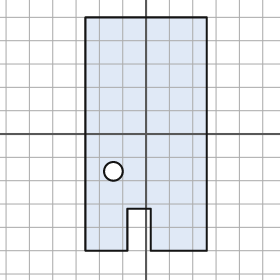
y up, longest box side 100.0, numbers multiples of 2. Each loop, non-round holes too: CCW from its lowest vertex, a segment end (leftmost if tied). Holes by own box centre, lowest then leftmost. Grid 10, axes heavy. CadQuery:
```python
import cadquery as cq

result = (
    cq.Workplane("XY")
    .moveTo(-26.0, -50.0)
    .lineTo(-8.0, -50.0)
    .lineTo(-8.0, -32.0)
    .lineTo(2.0, -32.0)
    .lineTo(2.0, -50.0)
    .lineTo(26.0, -50.0)
    .lineTo(26.0, 50.0)
    .lineTo(-26.0, 50.0)
    .close()
    .moveTo(-14.0, -16.0)
    .circle(4.0)
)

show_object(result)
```